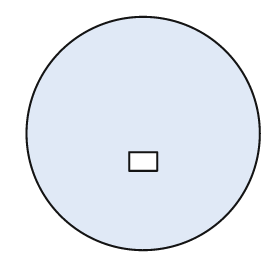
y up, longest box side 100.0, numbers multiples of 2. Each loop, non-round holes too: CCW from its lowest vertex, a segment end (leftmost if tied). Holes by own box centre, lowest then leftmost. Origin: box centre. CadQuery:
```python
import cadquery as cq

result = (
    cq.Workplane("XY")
    .moveTo(0.0, 0.0)
    .circle(50.0)
    .moveTo(-6.0, -16.0)
    .lineTo(6.0, -16.0)
    .lineTo(6.0, -8.0)
    .lineTo(-6.0, -8.0)
    .close()
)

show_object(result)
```